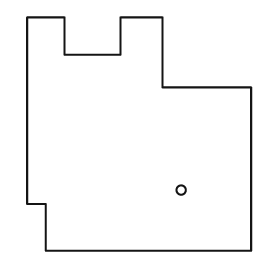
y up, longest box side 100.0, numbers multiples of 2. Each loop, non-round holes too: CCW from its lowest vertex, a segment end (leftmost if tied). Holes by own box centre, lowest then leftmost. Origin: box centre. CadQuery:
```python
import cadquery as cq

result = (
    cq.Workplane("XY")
    .moveTo(-40.0, -50.0)
    .lineTo(48.0, -50.0)
    .lineTo(48.0, 20.0)
    .lineTo(10.0, 20.0)
    .lineTo(10.0, 50.0)
    .lineTo(-8.0, 50.0)
    .lineTo(-8.0, 34.0)
    .lineTo(-32.0, 34.0)
    .lineTo(-32.0, 50.0)
    .lineTo(-48.0, 50.0)
    .lineTo(-48.0, -30.0)
    .lineTo(-40.0, -30.0)
    .close()
    .moveTo(18.0, -24.0)
    .circle(2.0)
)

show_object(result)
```